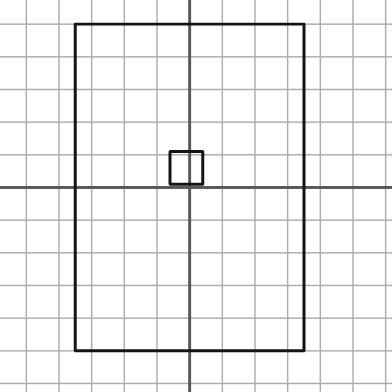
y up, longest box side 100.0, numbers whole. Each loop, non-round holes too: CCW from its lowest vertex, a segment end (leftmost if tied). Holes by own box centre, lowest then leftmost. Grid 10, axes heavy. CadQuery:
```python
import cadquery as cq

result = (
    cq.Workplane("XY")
    .moveTo(-35.0, -50.0)
    .lineTo(35.0, -50.0)
    .lineTo(35.0, 50.0)
    .lineTo(-35.0, 50.0)
    .close()
    .moveTo(-6.0, 1.0)
    .lineTo(4.0, 1.0)
    .lineTo(4.0, 11.0)
    .lineTo(-6.0, 11.0)
    .close()
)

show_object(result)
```